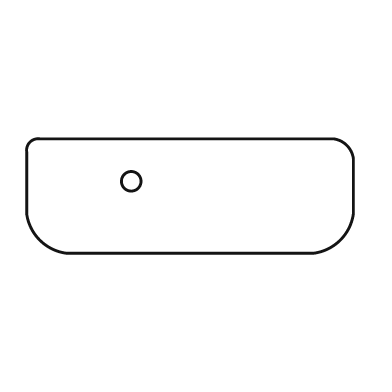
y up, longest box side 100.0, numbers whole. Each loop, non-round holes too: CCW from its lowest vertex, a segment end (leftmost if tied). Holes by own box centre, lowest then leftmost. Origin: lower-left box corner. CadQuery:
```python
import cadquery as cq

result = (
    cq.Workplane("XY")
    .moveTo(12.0, 0.0)
    .lineTo(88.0, 0.0)
    .threePointArc((96.0, 4.0), (100.0, 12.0))
    .lineTo(100.0, 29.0)
    .threePointArc((98.0, 33.0), (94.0, 35.0))
    .lineTo(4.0, 35.0)
    .threePointArc((1.0, 34.0), (0.0, 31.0))
    .lineTo(0.0, 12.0)
    .threePointArc((4.0, 4.0), (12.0, 0.0))
    .close()
    .moveTo(32.0, 22.0)
    .circle(3.0)
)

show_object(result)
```